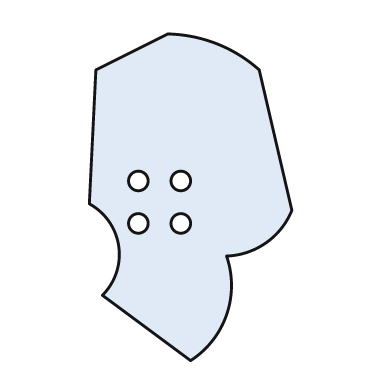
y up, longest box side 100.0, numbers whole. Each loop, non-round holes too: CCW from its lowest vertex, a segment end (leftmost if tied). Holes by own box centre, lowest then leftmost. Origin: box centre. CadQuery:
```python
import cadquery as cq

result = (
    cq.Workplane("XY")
    .moveTo(0.0, -50.0)
    .threePointArc((11.0, -36.0), (11.0, -18.0))
    .threePointArc((23.0, -14.0), (31.0, -4.0))
    .lineTo(21.0, 39.0)
    .threePointArc((8.0, 47.0), (-7.0, 50.0))
    .lineTo(-29.0, 39.0)
    .lineTo(-31.0, -2.0)
    .threePointArc((-22.0, -15.0), (-27.0, -30.0))
    .close()
    .moveTo(-16.0, -8.0)
    .circle(3.0)
    .moveTo(-3.0, -8.0)
    .circle(3.0)
    .moveTo(-16.0, 5.0)
    .circle(3.0)
    .moveTo(-3.0, 5.0)
    .circle(3.0)
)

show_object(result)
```